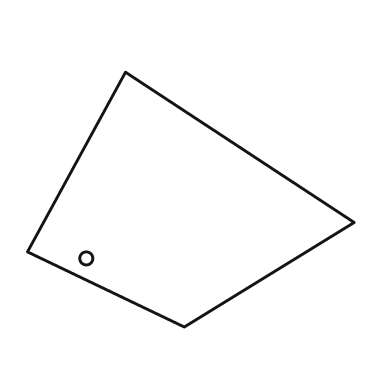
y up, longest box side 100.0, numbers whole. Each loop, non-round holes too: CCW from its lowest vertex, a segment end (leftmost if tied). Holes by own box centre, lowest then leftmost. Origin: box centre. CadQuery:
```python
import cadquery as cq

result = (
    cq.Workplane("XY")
    .moveTo(-2.0, -39.0)
    .lineTo(50.0, -7.0)
    .lineTo(-20.0, 39.0)
    .lineTo(-50.0, -16.0)
    .close()
    .moveTo(-32.0, -18.0)
    .circle(2.0)
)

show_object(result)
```